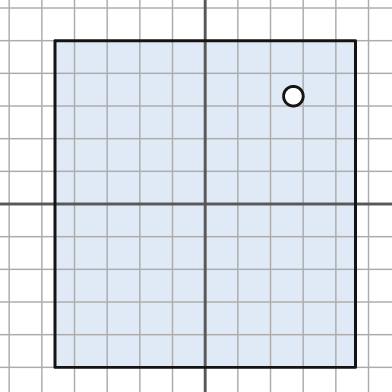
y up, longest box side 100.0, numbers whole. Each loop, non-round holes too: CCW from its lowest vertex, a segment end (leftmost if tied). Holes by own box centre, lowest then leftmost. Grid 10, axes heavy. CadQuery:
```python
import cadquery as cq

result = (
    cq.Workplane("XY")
    .moveTo(-46.0, -50.0)
    .lineTo(46.0, -50.0)
    .lineTo(46.0, 50.0)
    .lineTo(-46.0, 50.0)
    .close()
    .moveTo(27.0, 33.0)
    .circle(3.0)
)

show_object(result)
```